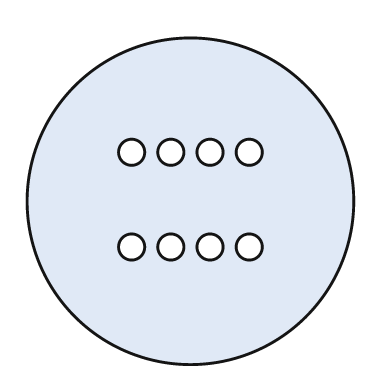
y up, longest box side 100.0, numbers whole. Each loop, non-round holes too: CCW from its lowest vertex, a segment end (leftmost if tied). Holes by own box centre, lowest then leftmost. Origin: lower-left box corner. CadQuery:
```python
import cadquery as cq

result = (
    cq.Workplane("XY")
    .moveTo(50.0, 50.0)
    .circle(50.0)
    .moveTo(32.0, 36.0)
    .circle(4.0)
    .moveTo(44.0, 36.0)
    .circle(4.0)
    .moveTo(56.0, 36.0)
    .circle(4.0)
    .moveTo(68.0, 36.0)
    .circle(4.0)
    .moveTo(32.0, 65.0)
    .circle(4.0)
    .moveTo(44.0, 65.0)
    .circle(4.0)
    .moveTo(56.0, 65.0)
    .circle(4.0)
    .moveTo(68.0, 65.0)
    .circle(4.0)
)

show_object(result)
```